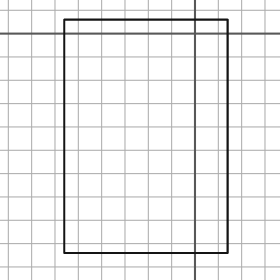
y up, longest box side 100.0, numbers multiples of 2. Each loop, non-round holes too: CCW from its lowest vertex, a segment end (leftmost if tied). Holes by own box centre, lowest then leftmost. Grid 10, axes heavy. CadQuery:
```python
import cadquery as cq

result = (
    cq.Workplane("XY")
    .moveTo(-56.0, -94.0)
    .lineTo(14.0, -94.0)
    .lineTo(14.0, 6.0)
    .lineTo(-56.0, 6.0)
    .close()
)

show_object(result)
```